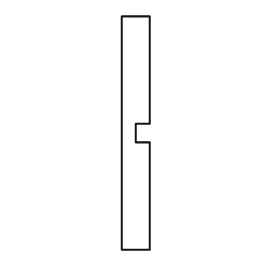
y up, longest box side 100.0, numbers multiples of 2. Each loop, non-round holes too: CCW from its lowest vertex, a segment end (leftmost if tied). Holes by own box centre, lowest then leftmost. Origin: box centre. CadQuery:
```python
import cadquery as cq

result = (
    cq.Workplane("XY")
    .moveTo(-6.0, -50.0)
    .lineTo(6.0, -50.0)
    .lineTo(6.0, -4.0)
    .lineTo(0.0, -4.0)
    .lineTo(0.0, 4.0)
    .lineTo(6.0, 4.0)
    .lineTo(6.0, 50.0)
    .lineTo(-6.0, 50.0)
    .close()
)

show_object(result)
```